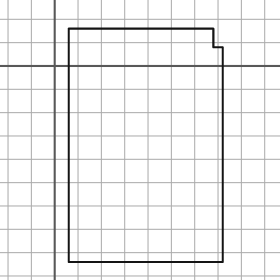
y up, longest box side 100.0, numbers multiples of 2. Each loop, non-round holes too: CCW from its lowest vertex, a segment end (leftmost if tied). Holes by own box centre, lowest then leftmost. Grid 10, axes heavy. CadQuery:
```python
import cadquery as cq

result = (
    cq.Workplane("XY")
    .moveTo(6.0, -84.0)
    .lineTo(72.0, -84.0)
    .lineTo(72.0, 8.0)
    .lineTo(68.0, 8.0)
    .lineTo(68.0, 16.0)
    .lineTo(6.0, 16.0)
    .close()
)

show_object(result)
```